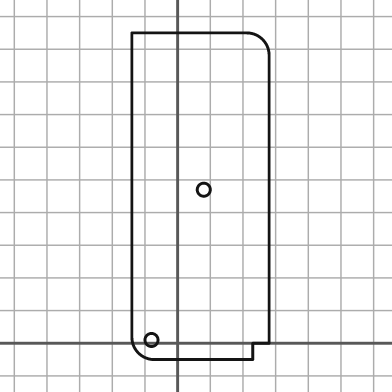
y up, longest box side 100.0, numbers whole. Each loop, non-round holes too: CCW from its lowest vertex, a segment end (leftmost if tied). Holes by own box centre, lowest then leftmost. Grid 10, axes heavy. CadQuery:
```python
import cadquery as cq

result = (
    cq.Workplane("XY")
    .moveTo(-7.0, -5.0)
    .lineTo(23.0, -5.0)
    .lineTo(23.0, 0.0)
    .lineTo(28.0, 0.0)
    .lineTo(28.0, 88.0)
    .threePointArc((26.0, 93.0), (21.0, 95.0))
    .lineTo(-14.0, 95.0)
    .lineTo(-14.0, 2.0)
    .threePointArc((-12.0, -3.0), (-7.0, -5.0))
    .close()
    .moveTo(-8.0, 1.0)
    .circle(2.0)
    .moveTo(8.0, 47.0)
    .circle(2.0)
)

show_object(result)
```